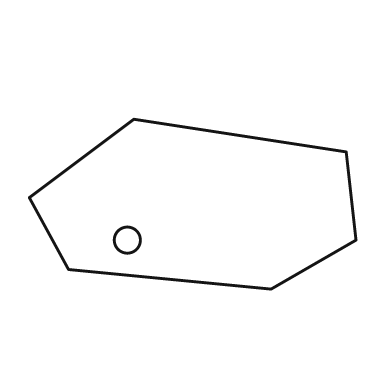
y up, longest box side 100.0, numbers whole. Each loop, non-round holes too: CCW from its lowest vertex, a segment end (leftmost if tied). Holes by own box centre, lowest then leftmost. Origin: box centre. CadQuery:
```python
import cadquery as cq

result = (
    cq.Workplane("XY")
    .moveTo(24.0, -26.0)
    .lineTo(50.0, -11.0)
    .lineTo(47.0, 16.0)
    .lineTo(-18.0, 26.0)
    .lineTo(-50.0, 2.0)
    .lineTo(-38.0, -20.0)
    .close()
    .moveTo(-20.0, -11.0)
    .circle(4.0)
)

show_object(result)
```